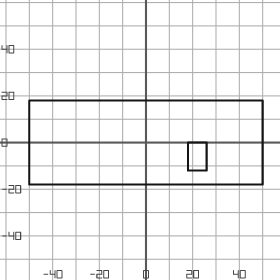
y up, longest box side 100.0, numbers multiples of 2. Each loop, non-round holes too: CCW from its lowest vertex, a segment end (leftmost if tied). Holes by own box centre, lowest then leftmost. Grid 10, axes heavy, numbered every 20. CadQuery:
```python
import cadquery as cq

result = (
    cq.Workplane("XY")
    .moveTo(-50.0, -18.0)
    .lineTo(50.0, -18.0)
    .lineTo(50.0, 18.0)
    .lineTo(-50.0, 18.0)
    .close()
    .moveTo(18.0, -12.0)
    .lineTo(26.0, -12.0)
    .lineTo(26.0, 0.0)
    .lineTo(18.0, 0.0)
    .close()
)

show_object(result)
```